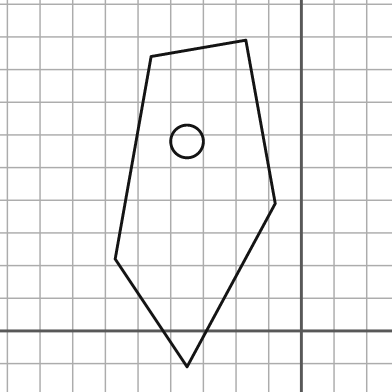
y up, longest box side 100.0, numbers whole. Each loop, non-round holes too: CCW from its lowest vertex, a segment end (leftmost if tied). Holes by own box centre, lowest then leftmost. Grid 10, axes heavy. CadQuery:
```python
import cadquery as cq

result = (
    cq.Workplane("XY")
    .moveTo(-35.0, -11.0)
    .lineTo(-8.0, 39.0)
    .lineTo(-17.0, 89.0)
    .lineTo(-46.0, 84.0)
    .lineTo(-57.0, 22.0)
    .close()
    .moveTo(-35.0, 58.0)
    .circle(5.0)
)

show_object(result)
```